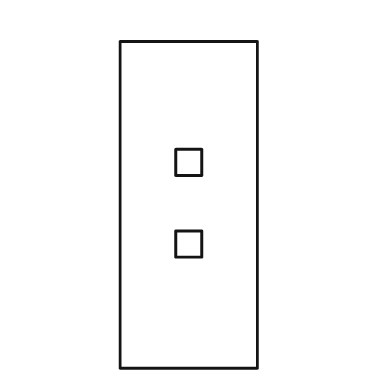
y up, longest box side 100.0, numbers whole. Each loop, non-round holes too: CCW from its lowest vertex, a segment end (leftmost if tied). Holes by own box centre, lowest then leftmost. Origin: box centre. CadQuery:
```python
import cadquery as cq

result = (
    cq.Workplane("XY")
    .moveTo(-21.0, -50.0)
    .lineTo(21.0, -50.0)
    .lineTo(21.0, 50.0)
    .lineTo(-21.0, 50.0)
    .close()
    .moveTo(-4.0, -16.0)
    .lineTo(4.0, -16.0)
    .lineTo(4.0, -8.0)
    .lineTo(-4.0, -8.0)
    .close()
    .moveTo(-4.0, 9.0)
    .lineTo(4.0, 9.0)
    .lineTo(4.0, 17.0)
    .lineTo(-4.0, 17.0)
    .close()
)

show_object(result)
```